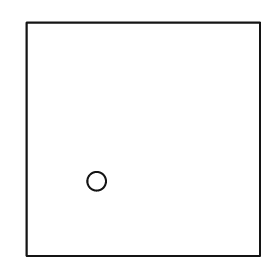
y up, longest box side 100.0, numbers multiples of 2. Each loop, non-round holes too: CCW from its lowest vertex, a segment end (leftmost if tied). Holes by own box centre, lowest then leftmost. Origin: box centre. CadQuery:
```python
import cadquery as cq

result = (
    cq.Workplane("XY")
    .moveTo(-50.0, -50.0)
    .lineTo(50.0, -50.0)
    .lineTo(50.0, 50.0)
    .lineTo(-50.0, 50.0)
    .close()
    .moveTo(-20.0, -18.0)
    .circle(4.0)
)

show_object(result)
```